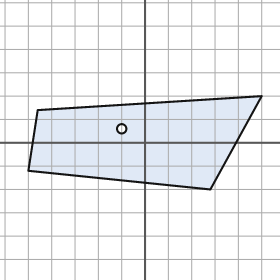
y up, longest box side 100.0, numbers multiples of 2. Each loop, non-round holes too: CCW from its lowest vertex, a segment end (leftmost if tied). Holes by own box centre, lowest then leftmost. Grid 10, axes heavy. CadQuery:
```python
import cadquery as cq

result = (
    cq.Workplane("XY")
    .moveTo(28.0, -20.0)
    .lineTo(50.0, 20.0)
    .lineTo(-46.0, 14.0)
    .lineTo(-50.0, -12.0)
    .close()
    .moveTo(-10.0, 6.0)
    .circle(2.0)
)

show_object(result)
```